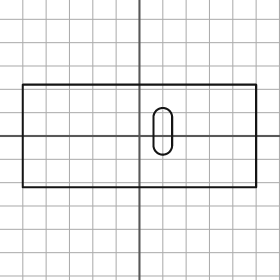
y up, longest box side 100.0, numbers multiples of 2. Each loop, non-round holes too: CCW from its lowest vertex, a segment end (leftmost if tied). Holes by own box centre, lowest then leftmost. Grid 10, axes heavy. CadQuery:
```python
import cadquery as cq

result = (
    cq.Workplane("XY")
    .moveTo(-50.0, -22.0)
    .lineTo(50.0, -22.0)
    .lineTo(50.0, 22.0)
    .lineTo(-50.0, 22.0)
    .close()
    .moveTo(6.0, -4.0)
    .threePointArc((10.0, -8.0), (14.0, -4.0))
    .lineTo(14.0, 8.0)
    .threePointArc((10.0, 12.0), (6.0, 8.0))
    .close()
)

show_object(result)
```